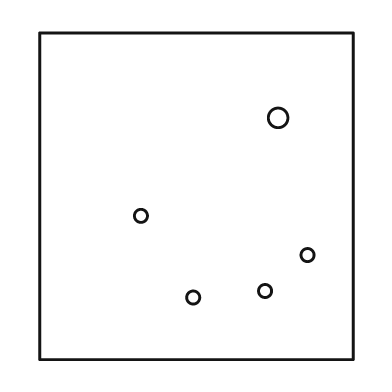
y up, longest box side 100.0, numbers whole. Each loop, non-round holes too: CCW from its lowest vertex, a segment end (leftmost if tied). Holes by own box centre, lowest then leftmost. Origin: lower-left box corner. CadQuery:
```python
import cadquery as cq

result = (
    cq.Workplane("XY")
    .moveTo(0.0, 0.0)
    .lineTo(96.0, 0.0)
    .lineTo(96.0, 100.0)
    .lineTo(0.0, 100.0)
    .close()
    .moveTo(47.0, 19.0)
    .circle(2.0)
    .moveTo(69.0, 21.0)
    .circle(2.0)
    .moveTo(82.0, 32.0)
    .circle(2.0)
    .moveTo(31.0, 44.0)
    .circle(2.0)
    .moveTo(73.0, 74.0)
    .circle(3.0)
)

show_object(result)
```